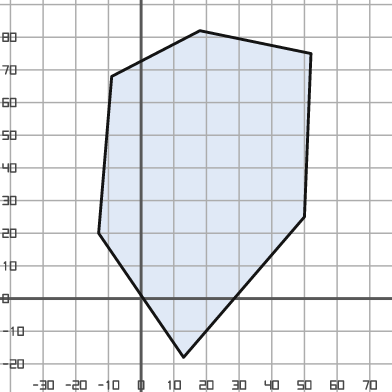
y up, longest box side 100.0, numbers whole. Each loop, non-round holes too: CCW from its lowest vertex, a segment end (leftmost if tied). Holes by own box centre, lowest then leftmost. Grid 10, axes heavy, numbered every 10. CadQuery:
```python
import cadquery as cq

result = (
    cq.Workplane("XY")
    .moveTo(13.0, -18.0)
    .lineTo(50.0, 25.0)
    .lineTo(52.0, 75.0)
    .lineTo(18.0, 82.0)
    .lineTo(-9.0, 68.0)
    .lineTo(-13.0, 20.0)
    .close()
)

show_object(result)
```